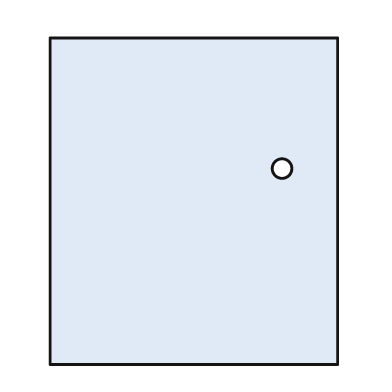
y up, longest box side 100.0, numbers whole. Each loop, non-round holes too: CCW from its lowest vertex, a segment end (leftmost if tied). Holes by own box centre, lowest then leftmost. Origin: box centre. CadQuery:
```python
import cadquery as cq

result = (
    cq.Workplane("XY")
    .moveTo(-44.0, -50.0)
    .lineTo(44.0, -50.0)
    .lineTo(44.0, 50.0)
    .lineTo(-44.0, 50.0)
    .close()
    .moveTo(27.0, 10.0)
    .circle(3.0)
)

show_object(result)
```